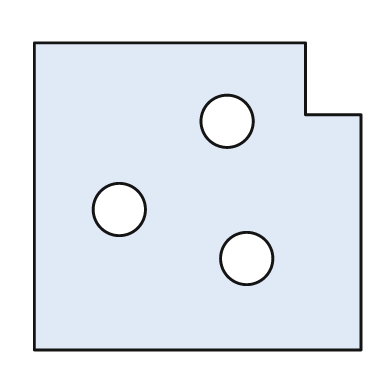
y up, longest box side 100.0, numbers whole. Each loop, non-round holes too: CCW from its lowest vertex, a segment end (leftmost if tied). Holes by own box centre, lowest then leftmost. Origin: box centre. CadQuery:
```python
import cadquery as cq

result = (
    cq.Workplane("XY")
    .moveTo(-50.0, -47.0)
    .lineTo(50.0, -47.0)
    .lineTo(50.0, 25.0)
    .lineTo(33.0, 25.0)
    .lineTo(33.0, 47.0)
    .lineTo(-50.0, 47.0)
    .close()
    .moveTo(15.0, -19.0)
    .circle(8.0)
    .moveTo(-24.0, -4.0)
    .circle(8.0)
    .moveTo(9.0, 23.0)
    .circle(8.0)
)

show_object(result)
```